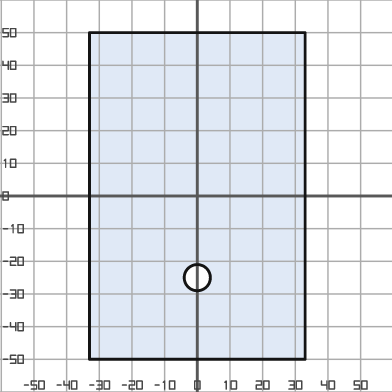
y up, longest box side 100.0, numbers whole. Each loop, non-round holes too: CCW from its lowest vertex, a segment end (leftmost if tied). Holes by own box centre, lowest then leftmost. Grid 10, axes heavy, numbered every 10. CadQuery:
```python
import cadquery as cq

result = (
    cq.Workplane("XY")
    .moveTo(-33.0, -50.0)
    .lineTo(33.0, -50.0)
    .lineTo(33.0, 50.0)
    .lineTo(-33.0, 50.0)
    .close()
    .moveTo(0.0, -25.0)
    .circle(4.0)
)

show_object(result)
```